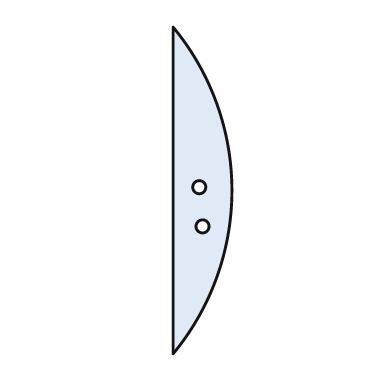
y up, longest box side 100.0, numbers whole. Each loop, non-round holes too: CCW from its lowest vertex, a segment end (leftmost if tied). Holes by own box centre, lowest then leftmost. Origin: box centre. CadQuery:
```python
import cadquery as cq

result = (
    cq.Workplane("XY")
    .moveTo(-9.0, -50.0)
    .threePointArc((9.0, 0.0), (-9.0, 50.0))
    .close()
    .moveTo(0.0, -11.0)
    .circle(2.0)
    .moveTo(-1.0, 1.0)
    .circle(2.0)
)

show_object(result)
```